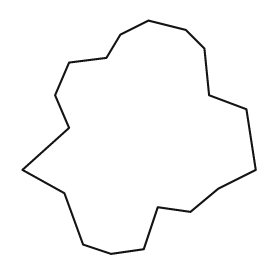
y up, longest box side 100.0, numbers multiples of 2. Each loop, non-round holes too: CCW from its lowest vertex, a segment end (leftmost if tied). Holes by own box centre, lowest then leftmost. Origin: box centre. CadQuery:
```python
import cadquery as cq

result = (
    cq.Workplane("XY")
    .moveTo(-12.0, -50.0)
    .lineTo(2.0, -48.0)
    .lineTo(8.0, -30.0)
    .lineTo(22.0, -32.0)
    .lineTo(34.0, -22.0)
    .lineTo(50.0, -14.0)
    .lineTo(46.0, 12.0)
    .lineTo(30.0, 18.0)
    .lineTo(28.0, 38.0)
    .lineTo(20.0, 46.0)
    .lineTo(4.0, 50.0)
    .lineTo(-8.0, 44.0)
    .lineTo(-14.0, 34.0)
    .lineTo(-30.0, 32.0)
    .lineTo(-36.0, 18.0)
    .lineTo(-30.0, 4.0)
    .lineTo(-50.0, -14.0)
    .lineTo(-32.0, -24.0)
    .lineTo(-24.0, -46.0)
    .close()
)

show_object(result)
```